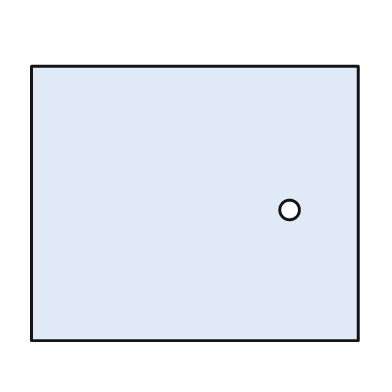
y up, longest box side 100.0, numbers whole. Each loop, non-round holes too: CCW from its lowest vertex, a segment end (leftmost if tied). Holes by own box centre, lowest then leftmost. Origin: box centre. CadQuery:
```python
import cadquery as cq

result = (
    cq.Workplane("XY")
    .moveTo(-50.0, -42.0)
    .lineTo(50.0, -42.0)
    .lineTo(50.0, 42.0)
    .lineTo(-50.0, 42.0)
    .close()
    .moveTo(29.0, -2.0)
    .circle(3.0)
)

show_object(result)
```